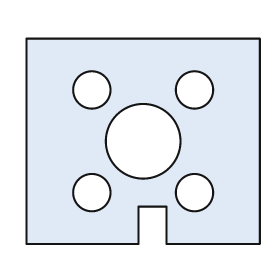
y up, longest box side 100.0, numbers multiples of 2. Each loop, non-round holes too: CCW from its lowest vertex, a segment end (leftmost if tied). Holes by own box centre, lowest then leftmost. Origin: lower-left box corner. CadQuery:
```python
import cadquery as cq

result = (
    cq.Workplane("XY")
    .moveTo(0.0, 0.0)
    .lineTo(48.0, 0.0)
    .lineTo(48.0, 16.0)
    .lineTo(60.0, 16.0)
    .lineTo(60.0, 0.0)
    .lineTo(100.0, 0.0)
    .lineTo(100.0, 88.0)
    .lineTo(0.0, 88.0)
    .close()
    .moveTo(28.0, 22.0)
    .circle(8.0)
    .moveTo(72.0, 22.0)
    .circle(8.0)
    .moveTo(50.0, 44.0)
    .circle(16.0)
    .moveTo(28.0, 66.0)
    .circle(8.0)
    .moveTo(72.0, 66.0)
    .circle(8.0)
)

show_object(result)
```